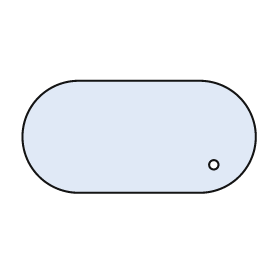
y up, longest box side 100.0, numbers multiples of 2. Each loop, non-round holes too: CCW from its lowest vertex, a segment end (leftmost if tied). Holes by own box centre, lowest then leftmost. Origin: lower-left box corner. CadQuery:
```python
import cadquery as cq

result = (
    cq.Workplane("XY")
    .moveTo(24.0, 0.0)
    .lineTo(76.0, 0.0)
    .threePointArc((100.0, 24.0), (76.0, 48.0))
    .lineTo(24.0, 48.0)
    .threePointArc((0.0, 24.0), (24.0, 0.0))
    .close()
    .moveTo(82.0, 12.0)
    .circle(2.0)
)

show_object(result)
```